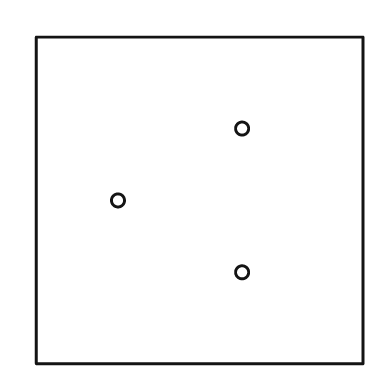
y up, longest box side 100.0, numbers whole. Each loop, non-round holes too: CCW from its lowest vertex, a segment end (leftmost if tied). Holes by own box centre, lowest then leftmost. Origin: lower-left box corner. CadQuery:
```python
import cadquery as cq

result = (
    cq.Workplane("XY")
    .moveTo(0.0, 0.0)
    .lineTo(100.0, 0.0)
    .lineTo(100.0, 100.0)
    .lineTo(0.0, 100.0)
    .close()
    .moveTo(63.0, 28.0)
    .circle(2.0)
    .moveTo(25.0, 50.0)
    .circle(2.0)
    .moveTo(63.0, 72.0)
    .circle(2.0)
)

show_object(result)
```